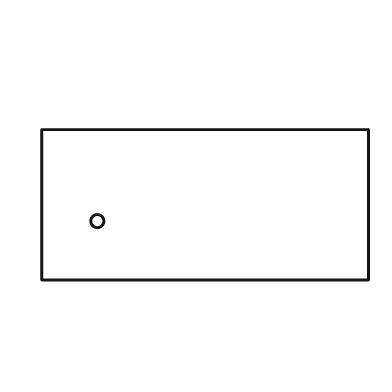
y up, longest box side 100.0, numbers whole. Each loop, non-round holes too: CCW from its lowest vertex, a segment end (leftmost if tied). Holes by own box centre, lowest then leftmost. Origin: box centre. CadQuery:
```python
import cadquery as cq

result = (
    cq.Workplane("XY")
    .moveTo(-50.0, -23.0)
    .lineTo(50.0, -23.0)
    .lineTo(50.0, 23.0)
    .lineTo(-50.0, 23.0)
    .close()
    .moveTo(-33.0, -5.0)
    .circle(2.0)
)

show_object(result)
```